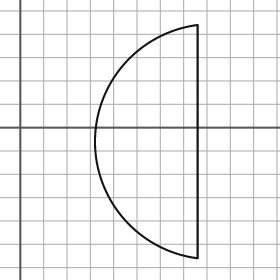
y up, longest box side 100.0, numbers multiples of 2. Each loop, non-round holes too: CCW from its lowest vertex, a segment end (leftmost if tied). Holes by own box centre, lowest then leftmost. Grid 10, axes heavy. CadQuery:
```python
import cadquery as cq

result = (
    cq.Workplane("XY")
    .moveTo(76.0, -56.0)
    .lineTo(76.0, 44.0)
    .threePointArc((32.0, -6.0), (76.0, -56.0))
    .close()
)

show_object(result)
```